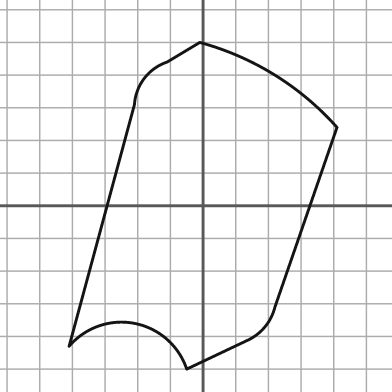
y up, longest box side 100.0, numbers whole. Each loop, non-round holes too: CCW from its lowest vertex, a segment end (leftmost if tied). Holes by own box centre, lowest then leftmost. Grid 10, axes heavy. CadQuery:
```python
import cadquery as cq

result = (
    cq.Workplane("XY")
    .moveTo(-5.0, -50.0)
    .lineTo(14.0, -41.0)
    .threePointArc((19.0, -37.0), (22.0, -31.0))
    .lineTo(41.0, 24.0)
    .threePointArc((22.0, 40.0), (-1.0, 50.0))
    .lineTo(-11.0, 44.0)
    .threePointArc((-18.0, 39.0), (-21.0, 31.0))
    .lineTo(-41.0, -43.0)
    .threePointArc((-21.0, -36.0), (-5.0, -50.0))
    .close()
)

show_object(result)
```